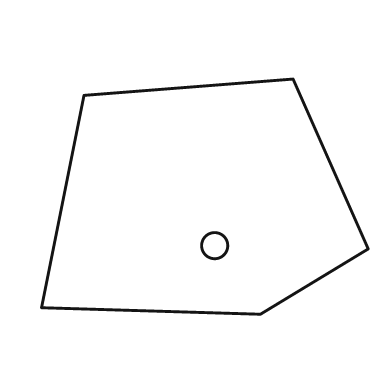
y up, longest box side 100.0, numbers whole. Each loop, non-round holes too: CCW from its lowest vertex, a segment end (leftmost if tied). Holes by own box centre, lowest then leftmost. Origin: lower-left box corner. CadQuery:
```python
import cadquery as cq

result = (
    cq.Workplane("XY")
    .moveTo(67.0, 0.0)
    .lineTo(100.0, 20.0)
    .lineTo(77.0, 72.0)
    .lineTo(13.0, 67.0)
    .lineTo(0.0, 2.0)
    .close()
    .moveTo(53.0, 21.0)
    .circle(4.0)
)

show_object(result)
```